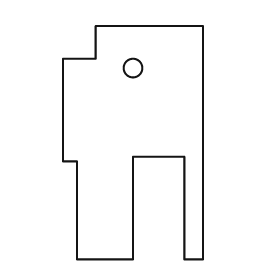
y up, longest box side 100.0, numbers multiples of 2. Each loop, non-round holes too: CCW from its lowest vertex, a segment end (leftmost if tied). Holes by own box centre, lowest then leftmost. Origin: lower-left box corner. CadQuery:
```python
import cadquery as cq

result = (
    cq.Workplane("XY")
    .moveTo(6.0, 0.0)
    .lineTo(30.0, 0.0)
    .lineTo(30.0, 44.0)
    .lineTo(52.0, 44.0)
    .lineTo(52.0, 0.0)
    .lineTo(60.0, 0.0)
    .lineTo(60.0, 100.0)
    .lineTo(14.0, 100.0)
    .lineTo(14.0, 86.0)
    .lineTo(0.0, 86.0)
    .lineTo(0.0, 42.0)
    .lineTo(6.0, 42.0)
    .close()
    .moveTo(30.0, 82.0)
    .circle(4.0)
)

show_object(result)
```